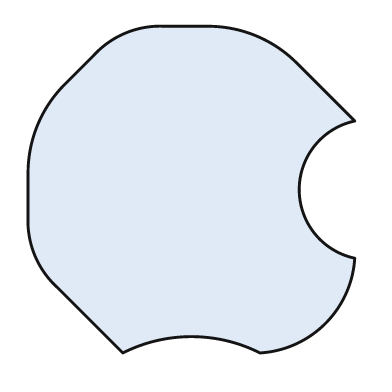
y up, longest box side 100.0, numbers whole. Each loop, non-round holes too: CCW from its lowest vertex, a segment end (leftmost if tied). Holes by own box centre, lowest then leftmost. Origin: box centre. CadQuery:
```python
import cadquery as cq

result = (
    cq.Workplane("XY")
    .moveTo(-21.0, -50.0)
    .threePointArc((0.0, -45.0), (21.0, -50.0))
    .threePointArc((41.0, -41.0), (50.0, -21.0))
    .threePointArc((33.0, 0.0), (50.0, 21.0))
    .lineTo(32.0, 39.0)
    .threePointArc((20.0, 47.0), (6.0, 50.0))
    .lineTo(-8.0, 50.0)
    .threePointArc((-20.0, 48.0), (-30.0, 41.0))
    .lineTo(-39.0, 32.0)
    .threePointArc((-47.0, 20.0), (-50.0, 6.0))
    .lineTo(-50.0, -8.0)
    .threePointArc((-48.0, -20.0), (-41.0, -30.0))
    .close()
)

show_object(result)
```